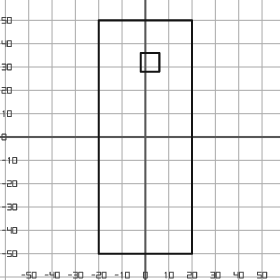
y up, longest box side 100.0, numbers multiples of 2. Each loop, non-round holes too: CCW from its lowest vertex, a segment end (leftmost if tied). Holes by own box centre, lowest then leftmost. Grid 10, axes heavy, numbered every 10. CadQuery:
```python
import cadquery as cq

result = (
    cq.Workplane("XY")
    .moveTo(-20.0, -50.0)
    .lineTo(20.0, -50.0)
    .lineTo(20.0, 50.0)
    .lineTo(-20.0, 50.0)
    .close()
    .moveTo(-2.0, 28.0)
    .lineTo(6.0, 28.0)
    .lineTo(6.0, 36.0)
    .lineTo(-2.0, 36.0)
    .close()
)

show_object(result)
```